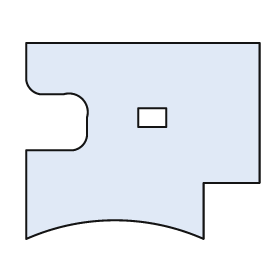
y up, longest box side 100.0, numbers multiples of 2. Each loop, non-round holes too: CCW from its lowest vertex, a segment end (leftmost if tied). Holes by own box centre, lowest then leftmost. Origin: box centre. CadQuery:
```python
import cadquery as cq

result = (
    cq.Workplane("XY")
    .moveTo(-50.0, -42.0)
    .threePointArc((-12.0, -34.0), (26.0, -42.0))
    .lineTo(26.0, -18.0)
    .lineTo(50.0, -18.0)
    .lineTo(50.0, 42.0)
    .lineTo(-50.0, 42.0)
    .lineTo(-50.0, 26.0)
    .threePointArc((-48.0, 22.0), (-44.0, 20.0))
    .lineTo(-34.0, 20.0)
    .threePointArc((-26.0, 18.0), (-24.0, 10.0))
    .lineTo(-24.0, 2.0)
    .threePointArc((-26.0, -2.0), (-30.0, -4.0))
    .lineTo(-50.0, -4.0)
    .close()
    .moveTo(-2.0, 6.0)
    .lineTo(10.0, 6.0)
    .lineTo(10.0, 14.0)
    .lineTo(-2.0, 14.0)
    .close()
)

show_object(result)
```